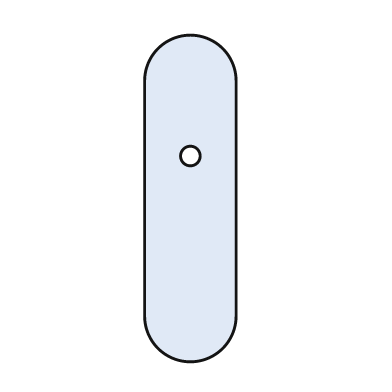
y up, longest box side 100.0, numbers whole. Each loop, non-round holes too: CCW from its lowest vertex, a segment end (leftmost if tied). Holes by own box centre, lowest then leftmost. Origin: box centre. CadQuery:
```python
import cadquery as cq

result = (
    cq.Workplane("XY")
    .moveTo(-14.0, -36.0)
    .threePointArc((0.0, -50.0), (14.0, -36.0))
    .lineTo(14.0, 36.0)
    .threePointArc((0.0, 50.0), (-14.0, 36.0))
    .close()
    .moveTo(0.0, 13.0)
    .circle(3.0)
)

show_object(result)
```